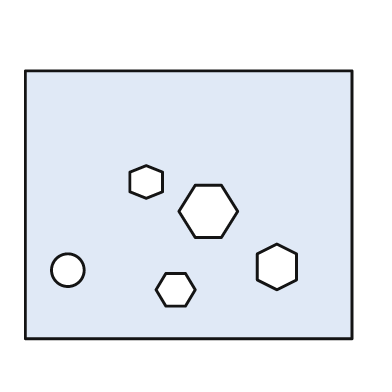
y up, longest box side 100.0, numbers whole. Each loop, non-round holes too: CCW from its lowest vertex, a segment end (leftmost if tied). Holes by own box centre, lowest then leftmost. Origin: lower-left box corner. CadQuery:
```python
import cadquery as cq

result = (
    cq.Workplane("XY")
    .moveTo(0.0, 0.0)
    .lineTo(100.0, 0.0)
    .lineTo(100.0, 82.0)
    .lineTo(0.0, 82.0)
    .close()
    .moveTo(43.0, 10.0)
    .lineTo(49.0, 10.0)
    .lineTo(52.0, 15.0)
    .lineTo(49.0, 20.0)
    .lineTo(43.0, 20.0)
    .lineTo(40.0, 15.0)
    .close()
    .moveTo(13.0, 21.0)
    .circle(5.0)
    .moveTo(77.0, 15.0)
    .lineTo(83.0, 18.0)
    .lineTo(83.0, 26.0)
    .lineTo(77.0, 29.0)
    .lineTo(71.0, 26.0)
    .lineTo(71.0, 18.0)
    .close()
    .moveTo(52.0, 31.0)
    .lineTo(60.0, 31.0)
    .lineTo(65.0, 39.0)
    .lineTo(60.0, 47.0)
    .lineTo(52.0, 47.0)
    .lineTo(47.0, 39.0)
    .close()
    .moveTo(37.0, 43.0)
    .lineTo(42.0, 45.0)
    .lineTo(42.0, 51.0)
    .lineTo(37.0, 53.0)
    .lineTo(32.0, 51.0)
    .lineTo(32.0, 45.0)
    .close()
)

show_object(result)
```